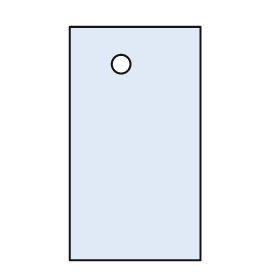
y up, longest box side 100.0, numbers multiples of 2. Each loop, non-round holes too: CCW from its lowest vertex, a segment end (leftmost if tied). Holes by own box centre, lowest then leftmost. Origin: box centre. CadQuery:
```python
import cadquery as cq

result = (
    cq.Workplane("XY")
    .moveTo(-28.0, -50.0)
    .lineTo(28.0, -50.0)
    .lineTo(28.0, 50.0)
    .lineTo(-28.0, 50.0)
    .close()
    .moveTo(-6.0, 34.0)
    .circle(4.0)
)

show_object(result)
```